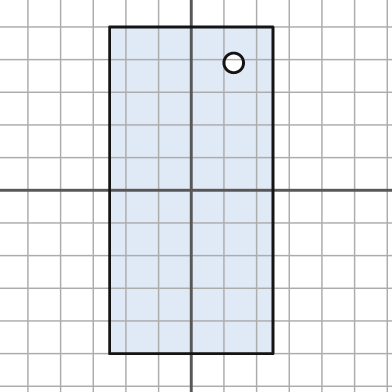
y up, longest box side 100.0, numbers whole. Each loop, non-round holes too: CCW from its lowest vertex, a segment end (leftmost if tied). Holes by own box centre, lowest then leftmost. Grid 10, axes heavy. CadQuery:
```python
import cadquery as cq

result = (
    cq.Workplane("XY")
    .moveTo(-25.0, -50.0)
    .lineTo(25.0, -50.0)
    .lineTo(25.0, 50.0)
    .lineTo(-25.0, 50.0)
    .close()
    .moveTo(13.0, 39.0)
    .circle(3.0)
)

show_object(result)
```